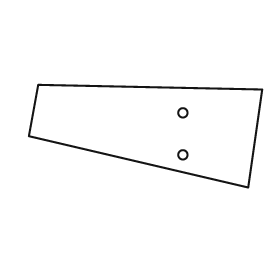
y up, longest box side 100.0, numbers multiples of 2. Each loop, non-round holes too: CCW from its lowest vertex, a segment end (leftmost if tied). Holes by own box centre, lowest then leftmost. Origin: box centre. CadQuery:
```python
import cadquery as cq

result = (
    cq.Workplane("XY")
    .moveTo(44.0, -22.0)
    .lineTo(50.0, 20.0)
    .lineTo(-46.0, 22.0)
    .lineTo(-50.0, 0.0)
    .close()
    .moveTo(16.0, -8.0)
    .circle(2.0)
    .moveTo(16.0, 10.0)
    .circle(2.0)
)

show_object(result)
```